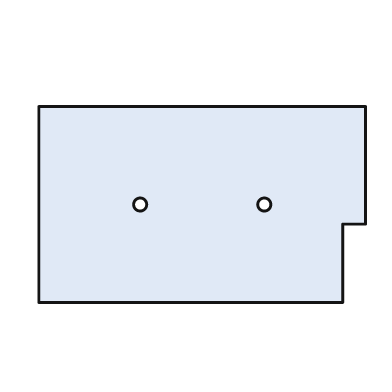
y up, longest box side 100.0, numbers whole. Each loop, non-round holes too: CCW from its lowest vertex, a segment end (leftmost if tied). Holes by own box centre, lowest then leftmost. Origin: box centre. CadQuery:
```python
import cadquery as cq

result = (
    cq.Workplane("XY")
    .moveTo(-50.0, -30.0)
    .lineTo(43.0, -30.0)
    .lineTo(43.0, -6.0)
    .lineTo(50.0, -6.0)
    .lineTo(50.0, 30.0)
    .lineTo(-50.0, 30.0)
    .close()
    .moveTo(-19.0, 0.0)
    .circle(2.0)
    .moveTo(19.0, 0.0)
    .circle(2.0)
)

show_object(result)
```